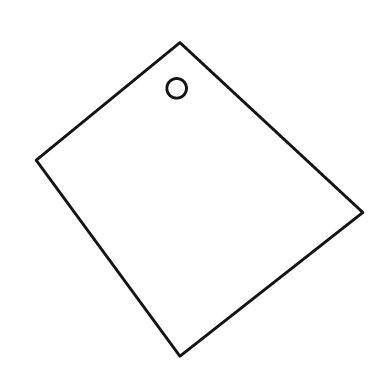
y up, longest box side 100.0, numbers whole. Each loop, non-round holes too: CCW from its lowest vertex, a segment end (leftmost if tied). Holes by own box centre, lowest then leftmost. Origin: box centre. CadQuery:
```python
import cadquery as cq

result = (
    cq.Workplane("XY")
    .moveTo(-6.0, -48.0)
    .lineTo(50.0, -4.0)
    .lineTo(-6.0, 48.0)
    .lineTo(-50.0, 12.0)
    .close()
    .moveTo(-7.0, 34.0)
    .circle(3.0)
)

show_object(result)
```